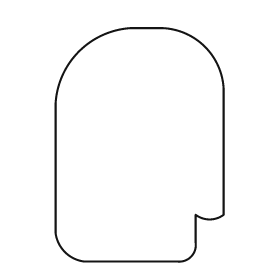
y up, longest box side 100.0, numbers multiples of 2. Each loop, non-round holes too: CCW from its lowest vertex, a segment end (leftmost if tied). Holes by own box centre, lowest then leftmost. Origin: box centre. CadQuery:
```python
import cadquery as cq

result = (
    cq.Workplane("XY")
    .moveTo(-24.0, -50.0)
    .lineTo(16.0, -50.0)
    .threePointArc((22.0, -48.0), (24.0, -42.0))
    .lineTo(24.0, -30.0)
    .threePointArc((30.0, -32.0), (36.0, -30.0))
    .lineTo(36.0, 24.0)
    .threePointArc((28.0, 42.0), (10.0, 50.0))
    .lineTo(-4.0, 50.0)
    .threePointArc((-26.0, 40.0), (-36.0, 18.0))
    .lineTo(-36.0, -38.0)
    .threePointArc((-32.0, -46.0), (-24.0, -50.0))
    .close()
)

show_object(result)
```